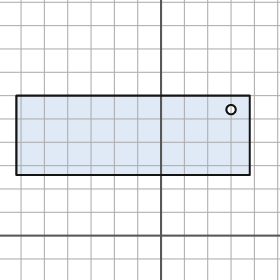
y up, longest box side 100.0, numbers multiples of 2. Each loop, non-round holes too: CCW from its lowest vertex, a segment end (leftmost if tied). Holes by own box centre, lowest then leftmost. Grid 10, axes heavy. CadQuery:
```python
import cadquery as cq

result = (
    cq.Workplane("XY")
    .moveTo(-62.0, 26.0)
    .lineTo(38.0, 26.0)
    .lineTo(38.0, 60.0)
    .lineTo(-62.0, 60.0)
    .close()
    .moveTo(30.0, 54.0)
    .circle(2.0)
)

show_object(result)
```